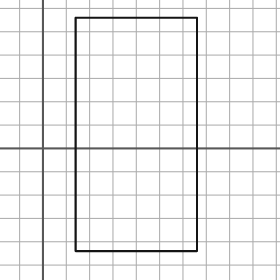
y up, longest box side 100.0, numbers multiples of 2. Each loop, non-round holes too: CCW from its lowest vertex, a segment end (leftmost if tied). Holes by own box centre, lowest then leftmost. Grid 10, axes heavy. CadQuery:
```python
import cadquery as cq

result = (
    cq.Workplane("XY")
    .moveTo(14.0, -44.0)
    .lineTo(66.0, -44.0)
    .lineTo(66.0, 56.0)
    .lineTo(14.0, 56.0)
    .close()
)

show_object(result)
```